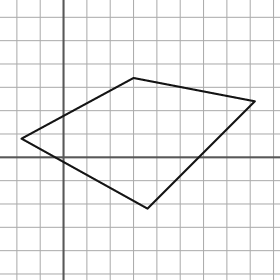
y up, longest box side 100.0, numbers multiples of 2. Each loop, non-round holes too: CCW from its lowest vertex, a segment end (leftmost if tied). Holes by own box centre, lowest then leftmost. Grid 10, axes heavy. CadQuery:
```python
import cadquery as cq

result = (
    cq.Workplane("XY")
    .moveTo(36.0, -22.0)
    .lineTo(82.0, 24.0)
    .lineTo(30.0, 34.0)
    .lineTo(-18.0, 8.0)
    .close()
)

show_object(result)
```